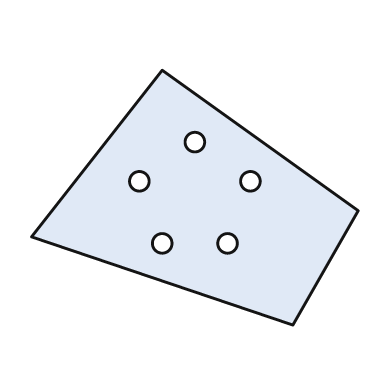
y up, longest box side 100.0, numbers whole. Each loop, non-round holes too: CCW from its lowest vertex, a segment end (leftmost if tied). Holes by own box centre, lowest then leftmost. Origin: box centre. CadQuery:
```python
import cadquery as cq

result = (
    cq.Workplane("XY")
    .moveTo(30.0, -39.0)
    .lineTo(50.0, -4.0)
    .lineTo(-10.0, 39.0)
    .lineTo(-50.0, -12.0)
    .close()
    .moveTo(-10.0, -14.0)
    .circle(3.0)
    .moveTo(10.0, -14.0)
    .circle(3.0)
    .moveTo(-17.0, 5.0)
    .circle(3.0)
    .moveTo(17.0, 5.0)
    .circle(3.0)
    .moveTo(0.0, 17.0)
    .circle(3.0)
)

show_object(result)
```